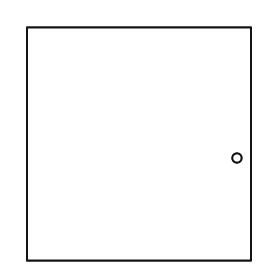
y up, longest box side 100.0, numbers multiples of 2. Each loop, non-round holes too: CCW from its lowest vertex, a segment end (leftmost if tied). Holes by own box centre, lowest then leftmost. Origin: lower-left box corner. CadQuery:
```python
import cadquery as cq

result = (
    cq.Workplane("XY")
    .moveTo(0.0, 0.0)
    .lineTo(96.0, 0.0)
    .lineTo(96.0, 100.0)
    .lineTo(0.0, 100.0)
    .close()
    .moveTo(90.0, 44.0)
    .circle(2.0)
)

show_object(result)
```